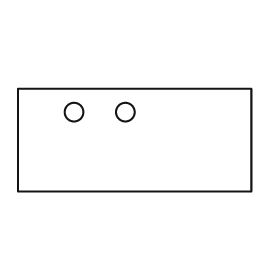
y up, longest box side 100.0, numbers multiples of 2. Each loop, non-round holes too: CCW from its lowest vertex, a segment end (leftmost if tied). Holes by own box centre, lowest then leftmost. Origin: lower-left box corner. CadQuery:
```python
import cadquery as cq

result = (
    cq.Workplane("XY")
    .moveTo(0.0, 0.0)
    .lineTo(100.0, 0.0)
    .lineTo(100.0, 44.0)
    .lineTo(0.0, 44.0)
    .close()
    .moveTo(24.0, 34.0)
    .circle(4.0)
    .moveTo(46.0, 34.0)
    .circle(4.0)
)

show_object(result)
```